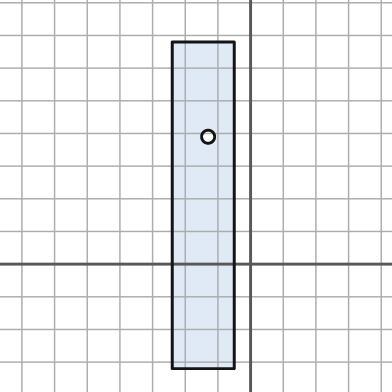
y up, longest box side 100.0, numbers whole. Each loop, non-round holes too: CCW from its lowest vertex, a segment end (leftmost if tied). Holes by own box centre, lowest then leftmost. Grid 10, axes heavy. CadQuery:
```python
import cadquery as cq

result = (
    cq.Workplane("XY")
    .moveTo(-24.0, -32.0)
    .lineTo(-5.0, -32.0)
    .lineTo(-5.0, 68.0)
    .lineTo(-24.0, 68.0)
    .close()
    .moveTo(-13.0, 39.0)
    .circle(2.0)
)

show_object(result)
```